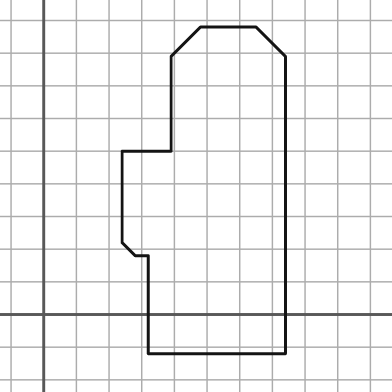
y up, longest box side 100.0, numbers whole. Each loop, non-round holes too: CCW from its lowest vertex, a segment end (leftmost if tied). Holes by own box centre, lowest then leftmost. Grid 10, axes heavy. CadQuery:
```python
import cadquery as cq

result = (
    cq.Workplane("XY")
    .moveTo(32.0, -12.0)
    .lineTo(74.0, -12.0)
    .lineTo(74.0, 79.0)
    .lineTo(65.0, 88.0)
    .lineTo(48.0, 88.0)
    .lineTo(39.0, 79.0)
    .lineTo(39.0, 50.0)
    .lineTo(24.0, 50.0)
    .lineTo(24.0, 22.0)
    .lineTo(28.0, 18.0)
    .lineTo(32.0, 18.0)
    .close()
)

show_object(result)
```